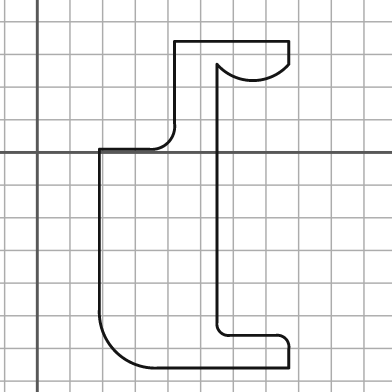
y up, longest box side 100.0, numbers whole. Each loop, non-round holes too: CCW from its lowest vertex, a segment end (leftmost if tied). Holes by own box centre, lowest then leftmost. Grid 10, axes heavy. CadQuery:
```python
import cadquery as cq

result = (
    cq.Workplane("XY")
    .moveTo(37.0, -66.0)
    .lineTo(77.0, -66.0)
    .lineTo(77.0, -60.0)
    .threePointArc((76.0, -57.0), (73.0, -56.0))
    .lineTo(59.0, -56.0)
    .threePointArc((56.0, -55.0), (55.0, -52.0))
    .lineTo(55.0, 27.0)
    .threePointArc((66.0, 22.0), (77.0, 27.0))
    .lineTo(77.0, 34.0)
    .lineTo(42.0, 34.0)
    .lineTo(42.0, 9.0)
    .threePointArc((40.0, 3.0), (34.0, 1.0))
    .lineTo(19.0, 1.0)
    .lineTo(19.0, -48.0)
    .threePointArc((24.0, -61.0), (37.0, -66.0))
    .close()
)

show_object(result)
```